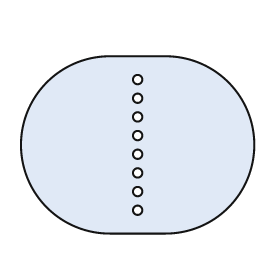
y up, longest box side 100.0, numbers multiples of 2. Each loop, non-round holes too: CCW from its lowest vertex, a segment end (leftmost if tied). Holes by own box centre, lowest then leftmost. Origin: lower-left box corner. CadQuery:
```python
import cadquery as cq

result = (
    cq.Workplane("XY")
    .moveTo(38.0, 0.0)
    .lineTo(62.0, 0.0)
    .threePointArc((100.0, 38.0), (62.0, 76.0))
    .lineTo(38.0, 76.0)
    .threePointArc((0.0, 38.0), (38.0, 0.0))
    .close()
    .moveTo(50.0, 10.0)
    .circle(2.0)
    .moveTo(50.0, 18.0)
    .circle(2.0)
    .moveTo(50.0, 26.0)
    .circle(2.0)
    .moveTo(50.0, 34.0)
    .circle(2.0)
    .moveTo(50.0, 42.0)
    .circle(2.0)
    .moveTo(50.0, 50.0)
    .circle(2.0)
    .moveTo(50.0, 58.0)
    .circle(2.0)
    .moveTo(50.0, 66.0)
    .circle(2.0)
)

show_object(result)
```